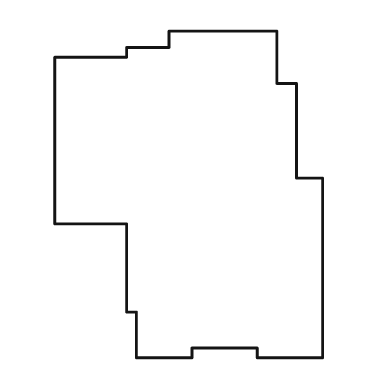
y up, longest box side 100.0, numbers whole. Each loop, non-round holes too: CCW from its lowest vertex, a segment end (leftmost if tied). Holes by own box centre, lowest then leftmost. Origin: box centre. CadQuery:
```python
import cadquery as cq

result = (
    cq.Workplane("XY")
    .moveTo(-16.0, -50.0)
    .lineTo(1.0, -50.0)
    .lineTo(1.0, -47.0)
    .lineTo(21.0, -47.0)
    .lineTo(21.0, -50.0)
    .lineTo(41.0, -50.0)
    .lineTo(41.0, 5.0)
    .lineTo(33.0, 5.0)
    .lineTo(33.0, 34.0)
    .lineTo(27.0, 34.0)
    .lineTo(27.0, 50.0)
    .lineTo(-6.0, 50.0)
    .lineTo(-6.0, 45.0)
    .lineTo(-19.0, 45.0)
    .lineTo(-19.0, 42.0)
    .lineTo(-41.0, 42.0)
    .lineTo(-41.0, -9.0)
    .lineTo(-19.0, -9.0)
    .lineTo(-19.0, -36.0)
    .lineTo(-16.0, -36.0)
    .close()
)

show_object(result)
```